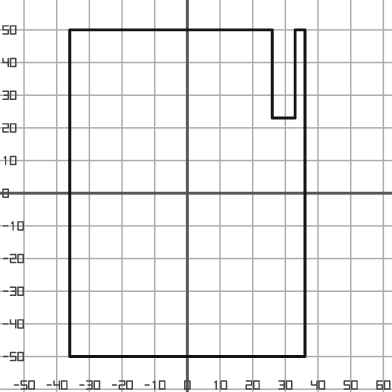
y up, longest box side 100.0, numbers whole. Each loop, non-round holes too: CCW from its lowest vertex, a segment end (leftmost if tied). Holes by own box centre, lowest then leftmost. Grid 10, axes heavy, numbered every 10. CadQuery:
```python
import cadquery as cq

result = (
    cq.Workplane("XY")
    .moveTo(-36.0, -50.0)
    .lineTo(36.0, -50.0)
    .lineTo(36.0, 50.0)
    .lineTo(33.0, 50.0)
    .lineTo(33.0, 23.0)
    .lineTo(26.0, 23.0)
    .lineTo(26.0, 50.0)
    .lineTo(-36.0, 50.0)
    .close()
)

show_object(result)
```